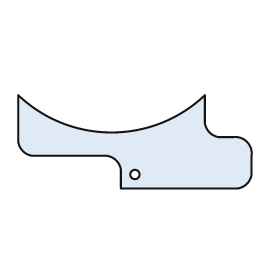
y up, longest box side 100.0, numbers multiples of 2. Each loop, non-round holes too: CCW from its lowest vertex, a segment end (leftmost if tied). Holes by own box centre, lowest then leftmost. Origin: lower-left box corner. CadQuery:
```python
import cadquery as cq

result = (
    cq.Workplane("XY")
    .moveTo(44.0, 0.0)
    .lineTo(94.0, 0.0)
    .threePointArc((98.0, 2.0), (100.0, 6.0))
    .lineTo(100.0, 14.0)
    .threePointArc((98.0, 20.0), (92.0, 22.0))
    .lineTo(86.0, 22.0)
    .threePointArc((82.0, 24.0), (80.0, 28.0))
    .lineTo(80.0, 40.0)
    .threePointArc((40.0, 24.0), (0.0, 40.0))
    .lineTo(0.0, 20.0)
    .threePointArc((2.0, 16.0), (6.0, 14.0))
    .lineTo(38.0, 14.0)
    .threePointArc((42.0, 12.0), (44.0, 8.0))
    .close()
    .moveTo(50.0, 6.0)
    .circle(2.0)
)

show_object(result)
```